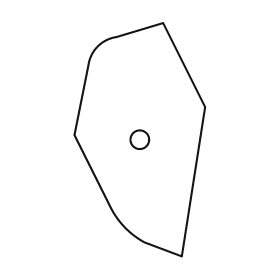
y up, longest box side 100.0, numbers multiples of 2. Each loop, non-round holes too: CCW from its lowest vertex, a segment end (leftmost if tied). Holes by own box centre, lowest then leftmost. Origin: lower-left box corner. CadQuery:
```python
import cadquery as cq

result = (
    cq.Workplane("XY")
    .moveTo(46.0, 0.0)
    .lineTo(56.0, 64.0)
    .lineTo(38.0, 100.0)
    .lineTo(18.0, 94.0)
    .threePointArc((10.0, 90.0), (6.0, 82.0))
    .lineTo(0.0, 52.0)
    .lineTo(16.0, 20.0)
    .threePointArc((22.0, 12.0), (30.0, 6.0))
    .close()
    .moveTo(28.0, 50.0)
    .circle(4.0)
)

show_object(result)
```